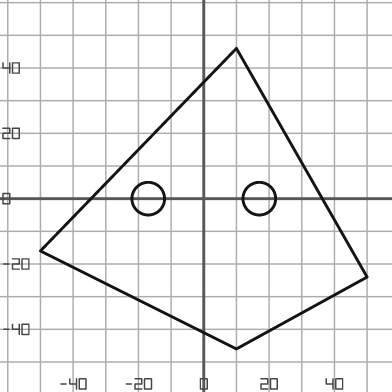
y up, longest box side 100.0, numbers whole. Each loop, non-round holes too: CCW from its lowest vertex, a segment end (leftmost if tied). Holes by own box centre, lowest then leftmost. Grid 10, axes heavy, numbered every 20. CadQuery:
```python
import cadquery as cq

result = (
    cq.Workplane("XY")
    .moveTo(10.0, -46.0)
    .lineTo(50.0, -24.0)
    .lineTo(10.0, 46.0)
    .lineTo(-50.0, -16.0)
    .close()
    .moveTo(-17.0, 0.0)
    .circle(5.0)
    .moveTo(17.0, 0.0)
    .circle(5.0)
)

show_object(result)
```